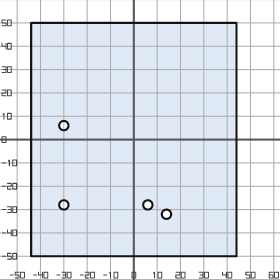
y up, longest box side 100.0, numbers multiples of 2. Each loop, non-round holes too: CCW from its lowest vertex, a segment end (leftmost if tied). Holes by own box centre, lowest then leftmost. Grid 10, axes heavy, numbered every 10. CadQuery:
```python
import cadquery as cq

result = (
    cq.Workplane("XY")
    .moveTo(-44.0, -50.0)
    .lineTo(44.0, -50.0)
    .lineTo(44.0, 50.0)
    .lineTo(-44.0, 50.0)
    .close()
    .moveTo(14.0, -32.0)
    .circle(2.0)
    .moveTo(-30.0, -28.0)
    .circle(2.0)
    .moveTo(6.0, -28.0)
    .circle(2.0)
    .moveTo(-30.0, 6.0)
    .circle(2.0)
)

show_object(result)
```